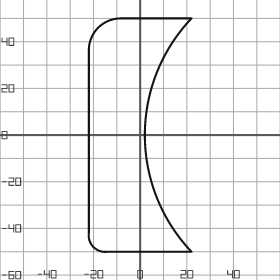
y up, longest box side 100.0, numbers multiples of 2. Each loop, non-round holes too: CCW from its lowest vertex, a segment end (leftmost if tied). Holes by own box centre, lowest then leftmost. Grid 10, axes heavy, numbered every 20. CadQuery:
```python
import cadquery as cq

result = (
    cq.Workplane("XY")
    .moveTo(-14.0, -50.0)
    .lineTo(22.0, -50.0)
    .threePointArc((2.0, 0.0), (22.0, 50.0))
    .lineTo(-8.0, 50.0)
    .threePointArc((-18.0, 46.0), (-22.0, 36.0))
    .lineTo(-22.0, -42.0)
    .threePointArc((-20.0, -48.0), (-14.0, -50.0))
    .close()
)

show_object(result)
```